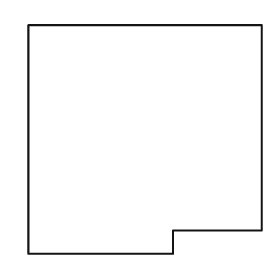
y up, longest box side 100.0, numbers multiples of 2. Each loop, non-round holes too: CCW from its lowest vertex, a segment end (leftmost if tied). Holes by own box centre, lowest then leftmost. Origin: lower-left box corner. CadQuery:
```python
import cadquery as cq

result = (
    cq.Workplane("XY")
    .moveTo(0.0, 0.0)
    .lineTo(62.0, 0.0)
    .lineTo(62.0, 10.0)
    .lineTo(100.0, 10.0)
    .lineTo(100.0, 98.0)
    .lineTo(0.0, 98.0)
    .close()
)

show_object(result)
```